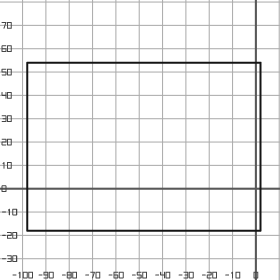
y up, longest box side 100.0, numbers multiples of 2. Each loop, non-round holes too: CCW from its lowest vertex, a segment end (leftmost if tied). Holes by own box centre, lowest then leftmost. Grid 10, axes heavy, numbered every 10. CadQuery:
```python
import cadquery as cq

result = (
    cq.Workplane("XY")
    .moveTo(-98.0, -18.0)
    .lineTo(2.0, -18.0)
    .lineTo(2.0, 54.0)
    .lineTo(-98.0, 54.0)
    .close()
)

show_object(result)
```